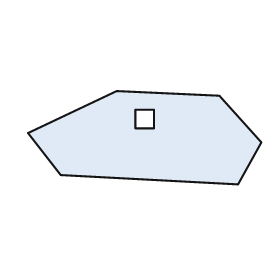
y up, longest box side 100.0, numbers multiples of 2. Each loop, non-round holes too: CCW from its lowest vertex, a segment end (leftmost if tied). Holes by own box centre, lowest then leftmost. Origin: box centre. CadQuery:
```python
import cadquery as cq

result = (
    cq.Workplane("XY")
    .moveTo(40.0, -20.0)
    .lineTo(50.0, -2.0)
    .lineTo(32.0, 18.0)
    .lineTo(-12.0, 20.0)
    .lineTo(-50.0, 2.0)
    .lineTo(-36.0, -16.0)
    .close()
    .moveTo(-4.0, 4.0)
    .lineTo(4.0, 4.0)
    .lineTo(4.0, 12.0)
    .lineTo(-4.0, 12.0)
    .close()
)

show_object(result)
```